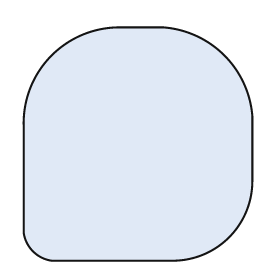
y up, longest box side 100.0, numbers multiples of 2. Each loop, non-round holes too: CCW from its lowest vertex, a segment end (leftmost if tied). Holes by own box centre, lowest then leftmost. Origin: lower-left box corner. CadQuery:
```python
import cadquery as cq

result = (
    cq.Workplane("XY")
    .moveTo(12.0, 0.0)
    .lineTo(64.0, 0.0)
    .threePointArc((88.0, 10.0), (98.0, 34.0))
    .lineTo(98.0, 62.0)
    .threePointArc((86.0, 88.0), (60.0, 100.0))
    .lineTo(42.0, 100.0)
    .threePointArc((12.0, 88.0), (0.0, 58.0))
    .lineTo(0.0, 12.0)
    .threePointArc((4.0, 4.0), (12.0, 0.0))
    .close()
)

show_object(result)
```